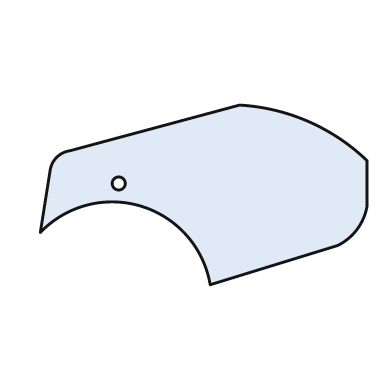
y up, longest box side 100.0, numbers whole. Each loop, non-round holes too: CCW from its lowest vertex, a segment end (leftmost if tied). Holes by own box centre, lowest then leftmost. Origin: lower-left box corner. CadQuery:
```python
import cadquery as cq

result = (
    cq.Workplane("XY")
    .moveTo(52.0, 0.0)
    .lineTo(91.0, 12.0)
    .threePointArc((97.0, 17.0), (100.0, 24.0))
    .lineTo(100.0, 38.0)
    .threePointArc((82.0, 50.0), (61.0, 55.0))
    .lineTo(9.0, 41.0)
    .threePointArc((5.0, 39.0), (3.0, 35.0))
    .lineTo(0.0, 16.0)
    .threePointArc((31.0, 24.0), (52.0, 0.0))
    .close()
    .moveTo(24.0, 31.0)
    .circle(2.0)
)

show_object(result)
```